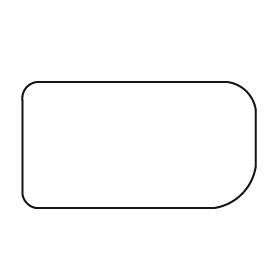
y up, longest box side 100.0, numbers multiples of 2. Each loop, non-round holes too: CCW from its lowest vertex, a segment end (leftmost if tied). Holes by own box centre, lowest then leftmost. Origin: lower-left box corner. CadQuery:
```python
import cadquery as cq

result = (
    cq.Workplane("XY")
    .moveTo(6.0, 0.0)
    .lineTo(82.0, 0.0)
    .threePointArc((94.0, 6.0), (100.0, 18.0))
    .lineTo(100.0, 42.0)
    .threePointArc((96.0, 50.0), (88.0, 54.0))
    .lineTo(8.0, 54.0)
    .threePointArc((2.0, 52.0), (0.0, 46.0))
    .lineTo(0.0, 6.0)
    .threePointArc((2.0, 2.0), (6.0, 0.0))
    .close()
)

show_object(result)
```